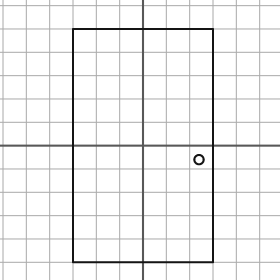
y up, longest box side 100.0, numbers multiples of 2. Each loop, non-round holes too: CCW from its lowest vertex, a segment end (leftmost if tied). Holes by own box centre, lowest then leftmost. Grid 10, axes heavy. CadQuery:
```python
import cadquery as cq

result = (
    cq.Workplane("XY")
    .moveTo(-30.0, -50.0)
    .lineTo(30.0, -50.0)
    .lineTo(30.0, 50.0)
    .lineTo(-30.0, 50.0)
    .close()
    .moveTo(24.0, -6.0)
    .circle(2.0)
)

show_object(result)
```